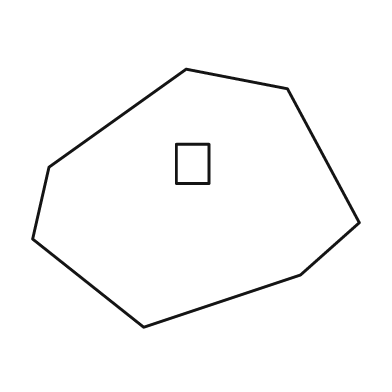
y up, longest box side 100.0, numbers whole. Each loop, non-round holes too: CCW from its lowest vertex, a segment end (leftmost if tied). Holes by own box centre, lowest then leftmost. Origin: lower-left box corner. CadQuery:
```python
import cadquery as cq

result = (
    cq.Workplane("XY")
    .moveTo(34.0, 0.0)
    .lineTo(82.0, 16.0)
    .lineTo(100.0, 32.0)
    .lineTo(78.0, 73.0)
    .lineTo(47.0, 79.0)
    .lineTo(5.0, 49.0)
    .lineTo(0.0, 27.0)
    .close()
    .moveTo(44.0, 44.0)
    .lineTo(54.0, 44.0)
    .lineTo(54.0, 56.0)
    .lineTo(44.0, 56.0)
    .close()
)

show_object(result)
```